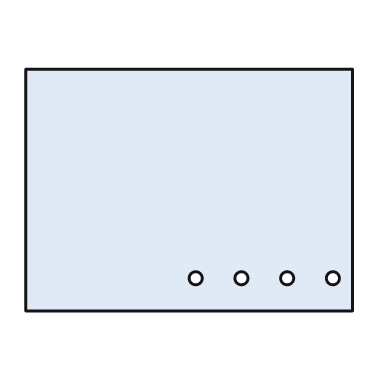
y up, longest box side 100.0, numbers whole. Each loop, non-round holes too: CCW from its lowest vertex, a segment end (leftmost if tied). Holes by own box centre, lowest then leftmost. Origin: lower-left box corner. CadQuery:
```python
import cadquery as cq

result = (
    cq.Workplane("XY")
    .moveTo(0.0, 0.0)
    .lineTo(100.0, 0.0)
    .lineTo(100.0, 74.0)
    .lineTo(0.0, 74.0)
    .close()
    .moveTo(52.0, 10.0)
    .circle(2.0)
    .moveTo(66.0, 10.0)
    .circle(2.0)
    .moveTo(80.0, 10.0)
    .circle(2.0)
    .moveTo(94.0, 10.0)
    .circle(2.0)
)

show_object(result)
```